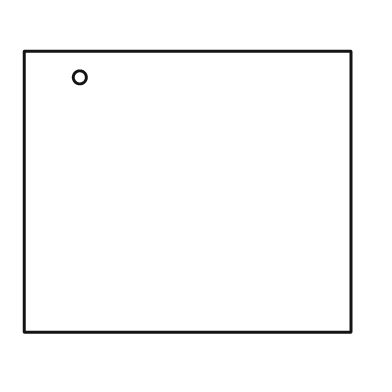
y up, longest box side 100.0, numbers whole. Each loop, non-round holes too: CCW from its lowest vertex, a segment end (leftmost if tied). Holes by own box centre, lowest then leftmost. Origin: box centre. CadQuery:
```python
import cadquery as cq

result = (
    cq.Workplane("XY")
    .moveTo(-50.0, -43.0)
    .lineTo(50.0, -43.0)
    .lineTo(50.0, 43.0)
    .lineTo(-50.0, 43.0)
    .close()
    .moveTo(-33.0, 35.0)
    .circle(2.0)
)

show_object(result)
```